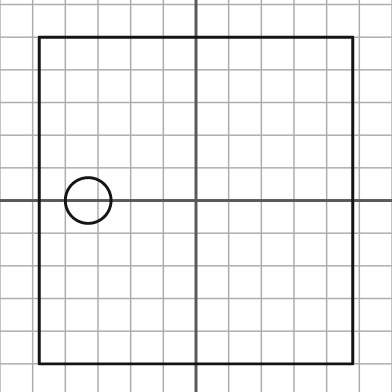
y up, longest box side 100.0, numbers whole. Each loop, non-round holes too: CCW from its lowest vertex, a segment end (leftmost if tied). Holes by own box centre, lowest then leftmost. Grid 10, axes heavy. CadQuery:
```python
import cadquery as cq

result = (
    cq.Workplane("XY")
    .moveTo(-48.0, -50.0)
    .lineTo(48.0, -50.0)
    .lineTo(48.0, 50.0)
    .lineTo(-48.0, 50.0)
    .close()
    .moveTo(-33.0, 0.0)
    .circle(7.0)
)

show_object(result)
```